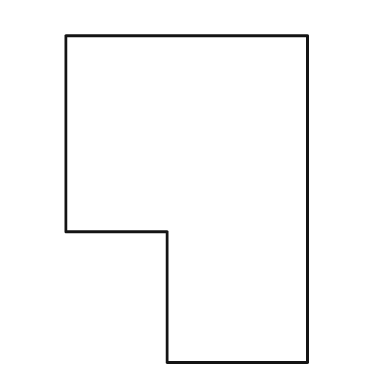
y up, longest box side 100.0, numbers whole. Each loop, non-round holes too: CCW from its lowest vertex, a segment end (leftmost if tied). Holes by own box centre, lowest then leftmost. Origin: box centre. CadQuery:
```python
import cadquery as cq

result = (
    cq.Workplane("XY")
    .moveTo(-6.0, -50.0)
    .lineTo(37.0, -50.0)
    .lineTo(37.0, 50.0)
    .lineTo(-37.0, 50.0)
    .lineTo(-37.0, -10.0)
    .lineTo(-6.0, -10.0)
    .close()
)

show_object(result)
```